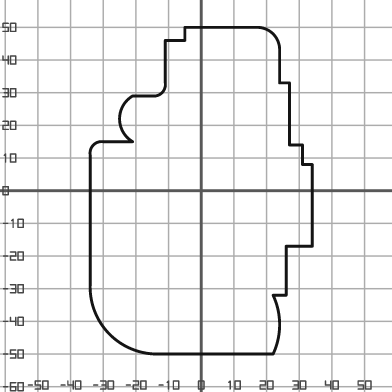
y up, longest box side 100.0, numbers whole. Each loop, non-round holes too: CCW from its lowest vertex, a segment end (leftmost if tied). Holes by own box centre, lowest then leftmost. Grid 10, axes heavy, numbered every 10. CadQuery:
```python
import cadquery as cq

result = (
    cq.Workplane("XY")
    .moveTo(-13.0, -50.0)
    .lineTo(22.0, -50.0)
    .threePointArc((24.0, -41.0), (22.0, -32.0))
    .lineTo(26.0, -32.0)
    .lineTo(26.0, -17.0)
    .lineTo(34.0, -17.0)
    .lineTo(34.0, 8.0)
    .lineTo(31.0, 8.0)
    .lineTo(31.0, 14.0)
    .lineTo(27.0, 14.0)
    .lineTo(27.0, 33.0)
    .lineTo(24.0, 33.0)
    .lineTo(24.0, 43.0)
    .threePointArc((22.0, 48.0), (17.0, 50.0))
    .lineTo(-5.0, 50.0)
    .lineTo(-5.0, 46.0)
    .lineTo(-11.0, 46.0)
    .lineTo(-11.0, 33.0)
    .threePointArc((-12.0, 30.0), (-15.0, 29.0))
    .lineTo(-21.0, 29.0)
    .threePointArc((-25.0, 22.0), (-21.0, 15.0))
    .lineTo(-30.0, 15.0)
    .threePointArc((-33.0, 14.0), (-34.0, 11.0))
    .lineTo(-34.0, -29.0)
    .threePointArc((-28.0, -44.0), (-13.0, -50.0))
    .close()
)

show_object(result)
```